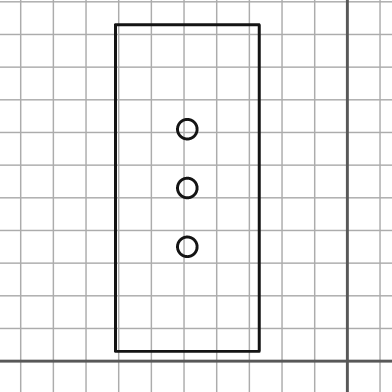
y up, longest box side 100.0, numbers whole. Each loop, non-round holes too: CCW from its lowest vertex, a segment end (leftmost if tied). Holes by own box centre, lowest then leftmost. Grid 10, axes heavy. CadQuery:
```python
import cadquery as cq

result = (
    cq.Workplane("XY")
    .moveTo(-71.0, 3.0)
    .lineTo(-27.0, 3.0)
    .lineTo(-27.0, 103.0)
    .lineTo(-71.0, 103.0)
    .close()
    .moveTo(-49.0, 35.0)
    .circle(3.0)
    .moveTo(-49.0, 53.0)
    .circle(3.0)
    .moveTo(-49.0, 71.0)
    .circle(3.0)
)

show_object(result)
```